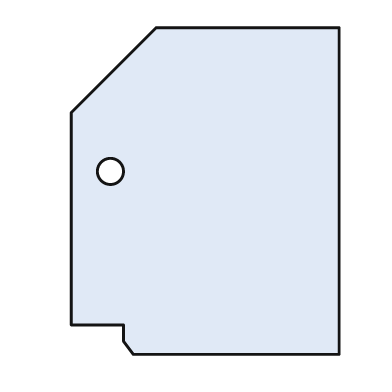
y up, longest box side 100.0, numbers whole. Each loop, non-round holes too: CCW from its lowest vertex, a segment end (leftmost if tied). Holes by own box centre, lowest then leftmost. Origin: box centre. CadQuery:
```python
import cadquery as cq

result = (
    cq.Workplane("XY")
    .moveTo(-22.0, -50.0)
    .lineTo(41.0, -50.0)
    .lineTo(41.0, 50.0)
    .lineTo(-15.0, 50.0)
    .lineTo(-41.0, 24.0)
    .lineTo(-41.0, -41.0)
    .lineTo(-25.0, -41.0)
    .lineTo(-25.0, -46.0)
    .close()
    .moveTo(-29.0, 6.0)
    .circle(4.0)
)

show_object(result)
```